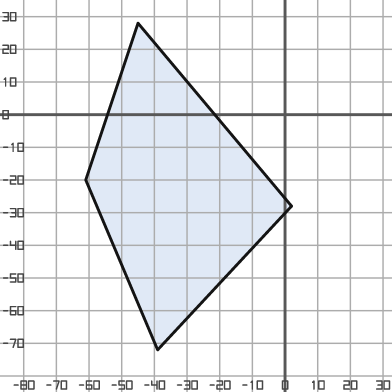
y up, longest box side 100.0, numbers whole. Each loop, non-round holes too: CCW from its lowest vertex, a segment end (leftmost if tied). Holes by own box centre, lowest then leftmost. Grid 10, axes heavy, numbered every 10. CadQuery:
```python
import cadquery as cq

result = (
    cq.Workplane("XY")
    .moveTo(-39.0, -72.0)
    .lineTo(2.0, -28.0)
    .lineTo(-45.0, 28.0)
    .lineTo(-61.0, -20.0)
    .close()
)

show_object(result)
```